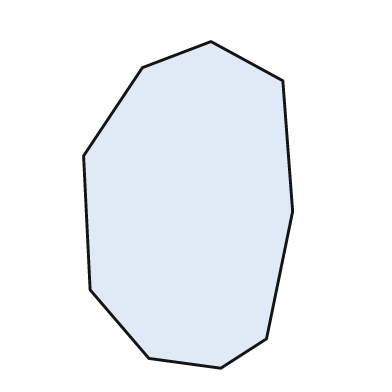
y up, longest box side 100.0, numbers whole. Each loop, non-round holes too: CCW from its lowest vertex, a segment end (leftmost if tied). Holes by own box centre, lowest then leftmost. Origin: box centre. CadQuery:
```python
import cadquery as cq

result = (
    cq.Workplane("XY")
    .moveTo(10.0, -50.0)
    .lineTo(24.0, -41.0)
    .lineTo(32.0, -2.0)
    .lineTo(29.0, 38.0)
    .lineTo(7.0, 50.0)
    .lineTo(-14.0, 42.0)
    .lineTo(-32.0, 15.0)
    .lineTo(-30.0, -26.0)
    .lineTo(-12.0, -47.0)
    .close()
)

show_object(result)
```